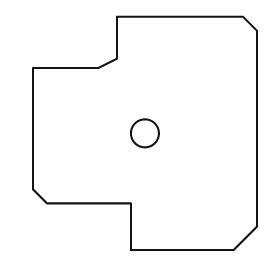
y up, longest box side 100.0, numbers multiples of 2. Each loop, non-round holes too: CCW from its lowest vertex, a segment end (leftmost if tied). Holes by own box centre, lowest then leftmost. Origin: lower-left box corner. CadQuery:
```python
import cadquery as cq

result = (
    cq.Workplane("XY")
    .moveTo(42.0, 0.0)
    .lineTo(86.0, 0.0)
    .lineTo(96.0, 10.0)
    .lineTo(96.0, 94.0)
    .lineTo(90.0, 100.0)
    .lineTo(36.0, 100.0)
    .lineTo(36.0, 82.0)
    .lineTo(28.0, 78.0)
    .lineTo(0.0, 78.0)
    .lineTo(0.0, 26.0)
    .lineTo(6.0, 20.0)
    .lineTo(42.0, 20.0)
    .close()
    .moveTo(48.0, 50.0)
    .circle(6.0)
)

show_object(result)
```